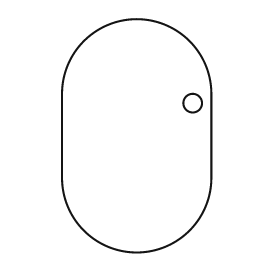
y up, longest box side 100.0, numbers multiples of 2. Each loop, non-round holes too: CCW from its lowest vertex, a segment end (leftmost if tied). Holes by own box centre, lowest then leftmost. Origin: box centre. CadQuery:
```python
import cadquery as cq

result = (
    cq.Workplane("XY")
    .moveTo(-32.0, -18.0)
    .threePointArc((0.0, -50.0), (32.0, -18.0))
    .lineTo(32.0, 18.0)
    .threePointArc((0.0, 50.0), (-32.0, 18.0))
    .close()
    .moveTo(24.0, 14.0)
    .circle(4.0)
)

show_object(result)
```